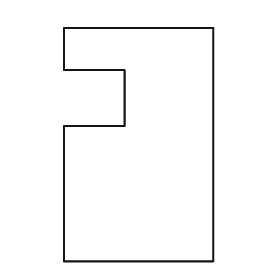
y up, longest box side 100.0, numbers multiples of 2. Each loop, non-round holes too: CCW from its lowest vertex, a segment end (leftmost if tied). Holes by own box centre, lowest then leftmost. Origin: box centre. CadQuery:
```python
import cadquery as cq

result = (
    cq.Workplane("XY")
    .moveTo(-32.0, -50.0)
    .lineTo(32.0, -50.0)
    .lineTo(32.0, 50.0)
    .lineTo(-32.0, 50.0)
    .lineTo(-32.0, 32.0)
    .lineTo(-6.0, 32.0)
    .lineTo(-6.0, 8.0)
    .lineTo(-32.0, 8.0)
    .close()
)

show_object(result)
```